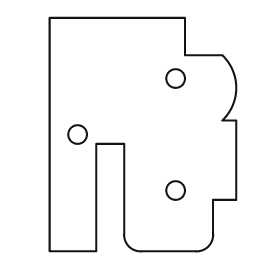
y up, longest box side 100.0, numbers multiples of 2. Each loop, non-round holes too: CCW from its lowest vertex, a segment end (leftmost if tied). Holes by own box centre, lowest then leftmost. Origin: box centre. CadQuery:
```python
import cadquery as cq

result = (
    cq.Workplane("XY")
    .moveTo(-40.0, -50.0)
    .lineTo(-20.0, -50.0)
    .lineTo(-20.0, -4.0)
    .lineTo(-8.0, -4.0)
    .lineTo(-8.0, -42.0)
    .threePointArc((-6.0, -48.0), (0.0, -50.0))
    .lineTo(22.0, -50.0)
    .threePointArc((28.0, -48.0), (30.0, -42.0))
    .lineTo(30.0, -28.0)
    .lineTo(40.0, -28.0)
    .lineTo(40.0, 6.0)
    .lineTo(34.0, 6.0)
    .threePointArc((40.0, 20.0), (34.0, 34.0))
    .lineTo(18.0, 34.0)
    .lineTo(18.0, 50.0)
    .lineTo(-40.0, 50.0)
    .close()
    .moveTo(14.0, -24.0)
    .circle(4.0)
    .moveTo(-28.0, 0.0)
    .circle(4.0)
    .moveTo(14.0, 24.0)
    .circle(4.0)
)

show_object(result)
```